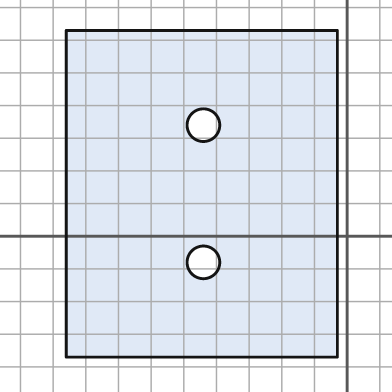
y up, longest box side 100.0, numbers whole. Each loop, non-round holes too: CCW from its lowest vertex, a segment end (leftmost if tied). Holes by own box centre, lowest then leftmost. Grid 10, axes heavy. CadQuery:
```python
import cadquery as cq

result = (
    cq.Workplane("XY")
    .moveTo(-86.0, -37.0)
    .lineTo(-3.0, -37.0)
    .lineTo(-3.0, 63.0)
    .lineTo(-86.0, 63.0)
    .close()
    .moveTo(-44.0, -8.0)
    .circle(5.0)
    .moveTo(-44.0, 34.0)
    .circle(5.0)
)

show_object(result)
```